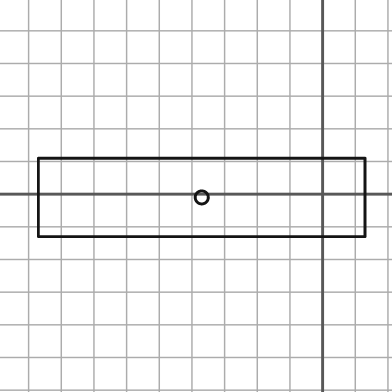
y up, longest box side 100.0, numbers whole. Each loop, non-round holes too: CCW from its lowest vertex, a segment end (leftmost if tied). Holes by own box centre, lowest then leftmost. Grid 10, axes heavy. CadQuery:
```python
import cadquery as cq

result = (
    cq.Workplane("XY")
    .moveTo(-87.0, -13.0)
    .lineTo(13.0, -13.0)
    .lineTo(13.0, 11.0)
    .lineTo(-87.0, 11.0)
    .close()
    .moveTo(-37.0, -1.0)
    .circle(2.0)
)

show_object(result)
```